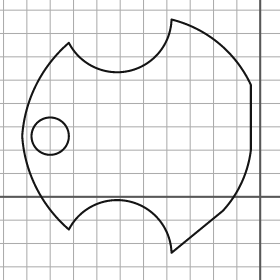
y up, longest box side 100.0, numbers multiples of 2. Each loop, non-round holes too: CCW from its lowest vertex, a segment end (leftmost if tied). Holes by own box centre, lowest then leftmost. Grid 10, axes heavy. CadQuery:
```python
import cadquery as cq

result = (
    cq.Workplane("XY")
    .moveTo(-38.0, -24.0)
    .lineTo(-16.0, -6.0)
    .threePointArc((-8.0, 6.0), (-4.0, 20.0))
    .lineTo(-4.0, 48.0)
    .threePointArc((-18.0, 66.0), (-38.0, 76.0))
    .threePointArc((-56.0, 54.0), (-82.0, 66.0))
    .threePointArc((-96.0, 48.0), (-102.0, 26.0))
    .threePointArc((-96.0, 4.0), (-82.0, -14.0))
    .threePointArc((-56.0, -2.0), (-38.0, -24.0))
    .close()
    .moveTo(-90.0, 26.0)
    .circle(8.0)
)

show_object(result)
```